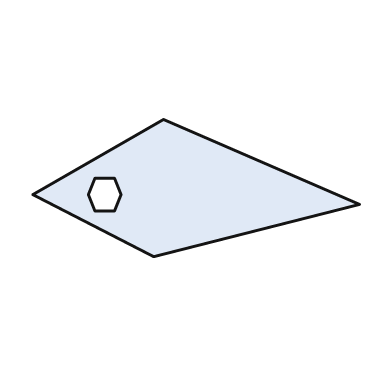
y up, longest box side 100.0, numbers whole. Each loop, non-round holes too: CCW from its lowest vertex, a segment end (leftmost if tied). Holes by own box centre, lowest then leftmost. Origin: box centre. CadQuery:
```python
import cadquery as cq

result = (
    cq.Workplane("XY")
    .moveTo(-13.0, -21.0)
    .lineTo(50.0, -5.0)
    .lineTo(-10.0, 21.0)
    .lineTo(-50.0, -2.0)
    .close()
    .moveTo(-31.0, -7.0)
    .lineTo(-25.0, -7.0)
    .lineTo(-23.0, -2.0)
    .lineTo(-25.0, 3.0)
    .lineTo(-31.0, 3.0)
    .lineTo(-33.0, -2.0)
    .close()
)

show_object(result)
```